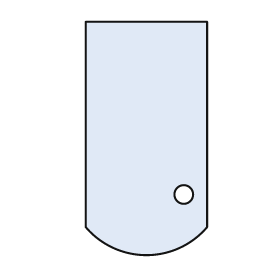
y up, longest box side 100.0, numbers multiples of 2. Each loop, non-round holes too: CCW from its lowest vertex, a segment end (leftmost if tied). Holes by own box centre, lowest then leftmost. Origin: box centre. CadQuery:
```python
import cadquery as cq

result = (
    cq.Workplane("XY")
    .moveTo(-26.0, -38.0)
    .threePointArc((0.0, -50.0), (26.0, -38.0))
    .lineTo(26.0, 50.0)
    .lineTo(-26.0, 50.0)
    .close()
    .moveTo(16.0, -24.0)
    .circle(4.0)
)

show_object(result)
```